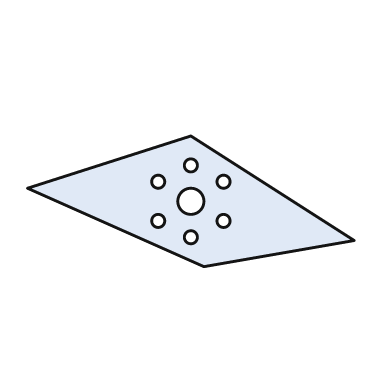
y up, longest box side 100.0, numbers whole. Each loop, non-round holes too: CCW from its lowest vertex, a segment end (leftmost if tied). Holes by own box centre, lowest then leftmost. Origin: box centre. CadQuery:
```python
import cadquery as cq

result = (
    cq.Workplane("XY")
    .moveTo(4.0, -20.0)
    .lineTo(50.0, -12.0)
    .lineTo(0.0, 20.0)
    .lineTo(-50.0, 4.0)
    .close()
    .moveTo(0.0, -11.0)
    .circle(2.0)
    .moveTo(-10.0, -6.0)
    .circle(2.0)
    .moveTo(10.0, -6.0)
    .circle(2.0)
    .moveTo(0.0, 0.0)
    .circle(4.0)
    .moveTo(-10.0, 6.0)
    .circle(2.0)
    .moveTo(10.0, 6.0)
    .circle(2.0)
    .moveTo(0.0, 11.0)
    .circle(2.0)
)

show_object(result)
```